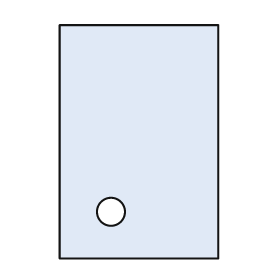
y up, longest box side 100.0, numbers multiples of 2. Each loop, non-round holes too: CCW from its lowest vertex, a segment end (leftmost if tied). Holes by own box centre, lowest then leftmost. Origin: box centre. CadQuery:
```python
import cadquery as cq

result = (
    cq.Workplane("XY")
    .moveTo(-34.0, -50.0)
    .lineTo(34.0, -50.0)
    .lineTo(34.0, 50.0)
    .lineTo(-34.0, 50.0)
    .close()
    .moveTo(-12.0, -30.0)
    .circle(6.0)
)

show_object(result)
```